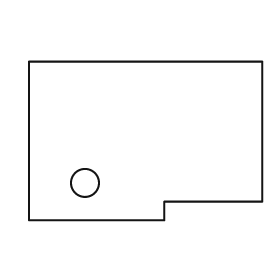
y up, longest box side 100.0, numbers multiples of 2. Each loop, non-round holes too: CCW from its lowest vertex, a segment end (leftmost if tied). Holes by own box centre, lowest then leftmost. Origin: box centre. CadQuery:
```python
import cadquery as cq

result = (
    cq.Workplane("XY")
    .moveTo(-50.0, -34.0)
    .lineTo(8.0, -34.0)
    .lineTo(8.0, -26.0)
    .lineTo(50.0, -26.0)
    .lineTo(50.0, 34.0)
    .lineTo(-50.0, 34.0)
    .close()
    .moveTo(-26.0, -18.0)
    .circle(6.0)
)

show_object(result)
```